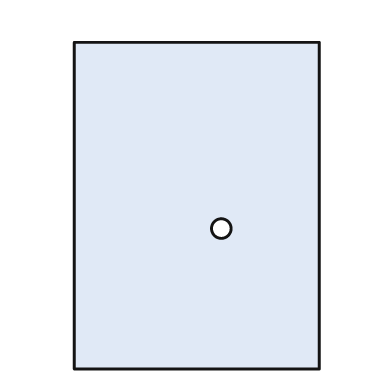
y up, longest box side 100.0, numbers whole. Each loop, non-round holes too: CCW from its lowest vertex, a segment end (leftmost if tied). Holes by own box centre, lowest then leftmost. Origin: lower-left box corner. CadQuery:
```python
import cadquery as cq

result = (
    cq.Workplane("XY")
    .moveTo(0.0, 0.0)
    .lineTo(75.0, 0.0)
    .lineTo(75.0, 100.0)
    .lineTo(0.0, 100.0)
    .close()
    .moveTo(45.0, 43.0)
    .circle(3.0)
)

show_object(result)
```